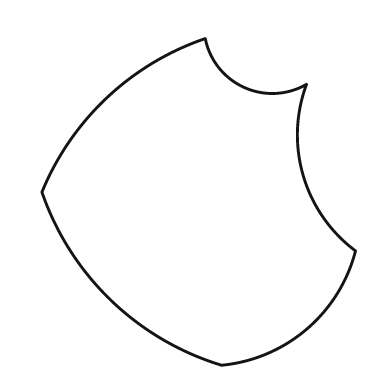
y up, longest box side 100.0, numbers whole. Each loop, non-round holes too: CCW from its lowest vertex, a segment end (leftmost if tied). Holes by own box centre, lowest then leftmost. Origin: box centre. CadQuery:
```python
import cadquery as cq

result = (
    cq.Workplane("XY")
    .moveTo(7.0, -50.0)
    .threePointArc((33.0, -39.0), (48.0, -15.0))
    .threePointArc((32.0, 8.0), (33.0, 36.0))
    .threePointArc((14.0, 35.0), (2.0, 50.0))
    .threePointArc((-28.0, 32.0), (-48.0, 3.0))
    .threePointArc((-27.0, -30.0), (7.0, -50.0))
    .close()
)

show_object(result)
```